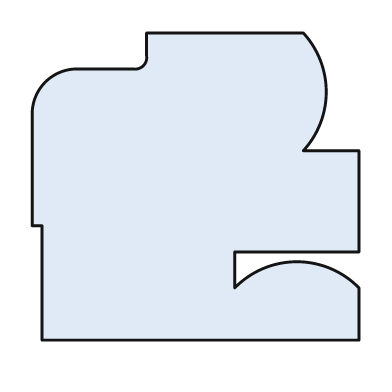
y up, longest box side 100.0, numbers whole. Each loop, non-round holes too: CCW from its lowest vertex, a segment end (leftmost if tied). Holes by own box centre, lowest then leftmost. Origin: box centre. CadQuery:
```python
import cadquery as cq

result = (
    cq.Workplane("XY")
    .moveTo(-47.0, -47.0)
    .lineTo(50.0, -47.0)
    .lineTo(50.0, -31.0)
    .threePointArc((31.0, -23.0), (12.0, -31.0))
    .lineTo(12.0, -20.0)
    .lineTo(50.0, -20.0)
    .lineTo(50.0, 11.0)
    .lineTo(33.0, 11.0)
    .threePointArc((40.0, 29.0), (33.0, 47.0))
    .lineTo(-15.0, 47.0)
    .lineTo(-15.0, 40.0)
    .threePointArc((-16.0, 37.0), (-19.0, 36.0))
    .lineTo(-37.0, 36.0)
    .threePointArc((-46.0, 32.0), (-50.0, 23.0))
    .lineTo(-50.0, -12.0)
    .lineTo(-47.0, -12.0)
    .close()
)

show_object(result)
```